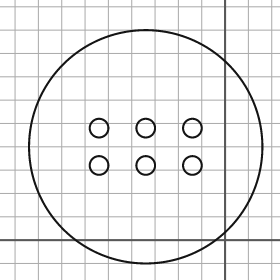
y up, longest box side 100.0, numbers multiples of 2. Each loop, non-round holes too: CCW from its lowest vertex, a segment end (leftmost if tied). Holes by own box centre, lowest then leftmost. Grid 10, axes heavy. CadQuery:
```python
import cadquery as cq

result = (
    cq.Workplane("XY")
    .moveTo(-34.0, 40.0)
    .circle(50.0)
    .moveTo(-54.0, 32.0)
    .circle(4.0)
    .moveTo(-34.0, 32.0)
    .circle(4.0)
    .moveTo(-14.0, 32.0)
    .circle(4.0)
    .moveTo(-54.0, 48.0)
    .circle(4.0)
    .moveTo(-34.0, 48.0)
    .circle(4.0)
    .moveTo(-14.0, 48.0)
    .circle(4.0)
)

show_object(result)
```